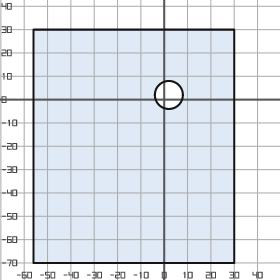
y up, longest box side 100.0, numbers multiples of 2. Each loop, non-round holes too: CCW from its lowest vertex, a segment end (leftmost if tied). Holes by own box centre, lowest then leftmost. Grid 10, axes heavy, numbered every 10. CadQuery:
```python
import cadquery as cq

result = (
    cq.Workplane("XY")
    .moveTo(-56.0, -70.0)
    .lineTo(30.0, -70.0)
    .lineTo(30.0, 30.0)
    .lineTo(-56.0, 30.0)
    .close()
    .moveTo(2.0, 2.0)
    .circle(6.0)
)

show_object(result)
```